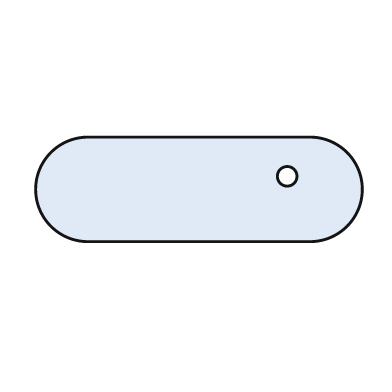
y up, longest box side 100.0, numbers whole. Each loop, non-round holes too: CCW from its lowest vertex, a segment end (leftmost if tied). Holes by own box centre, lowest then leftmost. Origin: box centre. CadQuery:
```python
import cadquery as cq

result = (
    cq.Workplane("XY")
    .moveTo(-34.0, -16.0)
    .lineTo(34.0, -16.0)
    .threePointArc((50.0, 0.0), (34.0, 16.0))
    .lineTo(-34.0, 16.0)
    .threePointArc((-50.0, 0.0), (-34.0, -16.0))
    .close()
    .moveTo(27.0, 4.0)
    .circle(3.0)
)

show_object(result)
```